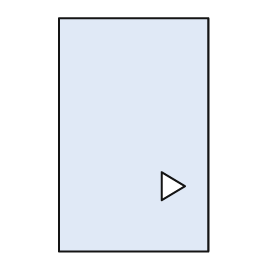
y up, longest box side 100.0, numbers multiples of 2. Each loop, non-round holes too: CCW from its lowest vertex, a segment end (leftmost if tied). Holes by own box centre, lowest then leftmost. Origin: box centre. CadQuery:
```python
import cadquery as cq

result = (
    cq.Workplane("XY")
    .moveTo(-32.0, -50.0)
    .lineTo(32.0, -50.0)
    .lineTo(32.0, 50.0)
    .lineTo(-32.0, 50.0)
    .close()
    .moveTo(12.0, -28.0)
    .lineTo(22.0, -22.0)
    .lineTo(12.0, -16.0)
    .close()
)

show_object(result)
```